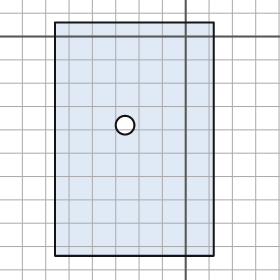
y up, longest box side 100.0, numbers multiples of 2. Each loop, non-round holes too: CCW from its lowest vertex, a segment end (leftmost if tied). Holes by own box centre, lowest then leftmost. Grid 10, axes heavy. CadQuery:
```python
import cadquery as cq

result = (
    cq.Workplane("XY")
    .moveTo(-56.0, -94.0)
    .lineTo(12.0, -94.0)
    .lineTo(12.0, 6.0)
    .lineTo(-56.0, 6.0)
    .close()
    .moveTo(-26.0, -38.0)
    .circle(4.0)
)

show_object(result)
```